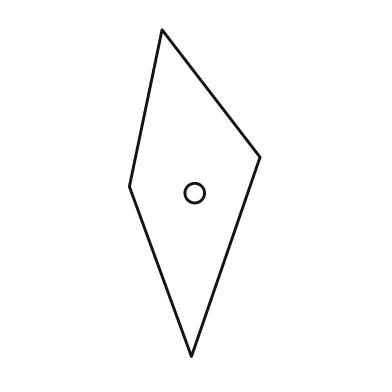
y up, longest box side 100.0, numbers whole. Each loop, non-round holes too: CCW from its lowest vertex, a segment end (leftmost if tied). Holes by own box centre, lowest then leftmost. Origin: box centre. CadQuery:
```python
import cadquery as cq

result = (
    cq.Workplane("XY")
    .moveTo(-1.0, -50.0)
    .lineTo(20.0, 11.0)
    .lineTo(-10.0, 50.0)
    .lineTo(-20.0, 2.0)
    .close()
    .moveTo(0.0, 0.0)
    .circle(3.0)
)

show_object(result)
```